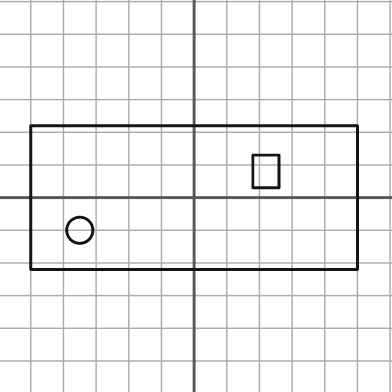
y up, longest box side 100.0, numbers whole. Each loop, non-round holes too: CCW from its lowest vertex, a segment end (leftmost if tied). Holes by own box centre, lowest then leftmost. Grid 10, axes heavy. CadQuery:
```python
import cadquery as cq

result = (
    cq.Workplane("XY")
    .moveTo(-50.0, -22.0)
    .lineTo(50.0, -22.0)
    .lineTo(50.0, 22.0)
    .lineTo(-50.0, 22.0)
    .close()
    .moveTo(-35.0, -10.0)
    .circle(4.0)
    .moveTo(18.0, 3.0)
    .lineTo(26.0, 3.0)
    .lineTo(26.0, 13.0)
    .lineTo(18.0, 13.0)
    .close()
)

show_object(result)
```